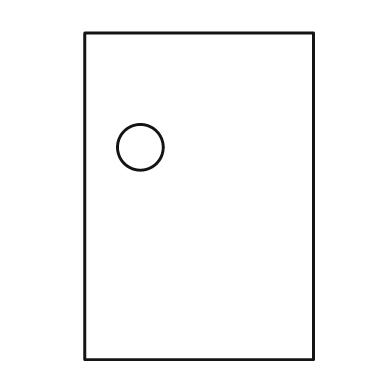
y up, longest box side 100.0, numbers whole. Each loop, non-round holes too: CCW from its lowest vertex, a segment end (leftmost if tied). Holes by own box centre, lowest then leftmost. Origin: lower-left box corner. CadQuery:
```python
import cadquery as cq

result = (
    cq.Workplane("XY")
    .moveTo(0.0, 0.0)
    .lineTo(70.0, 0.0)
    .lineTo(70.0, 100.0)
    .lineTo(0.0, 100.0)
    .close()
    .moveTo(17.0, 65.0)
    .circle(7.0)
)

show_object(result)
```